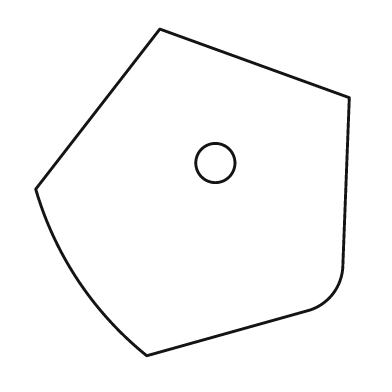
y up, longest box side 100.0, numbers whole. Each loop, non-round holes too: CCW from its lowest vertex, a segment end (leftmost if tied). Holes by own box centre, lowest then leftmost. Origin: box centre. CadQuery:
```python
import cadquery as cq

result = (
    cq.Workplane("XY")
    .moveTo(-14.0, -50.0)
    .lineTo(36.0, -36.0)
    .threePointArc((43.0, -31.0), (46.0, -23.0))
    .lineTo(48.0, 29.0)
    .lineTo(-10.0, 50.0)
    .lineTo(-48.0, 1.0)
    .threePointArc((-35.0, -27.0), (-14.0, -50.0))
    .close()
    .moveTo(7.0, 9.0)
    .circle(6.0)
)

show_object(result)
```